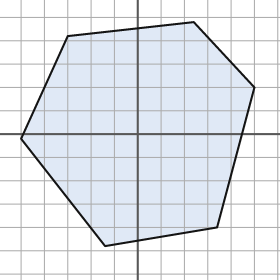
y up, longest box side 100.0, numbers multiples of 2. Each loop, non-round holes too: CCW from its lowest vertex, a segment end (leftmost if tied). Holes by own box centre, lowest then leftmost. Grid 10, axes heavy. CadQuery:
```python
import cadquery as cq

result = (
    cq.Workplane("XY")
    .moveTo(-14.0, -48.0)
    .lineTo(34.0, -40.0)
    .lineTo(50.0, 20.0)
    .lineTo(24.0, 48.0)
    .lineTo(-30.0, 42.0)
    .lineTo(-50.0, -2.0)
    .close()
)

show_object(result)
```